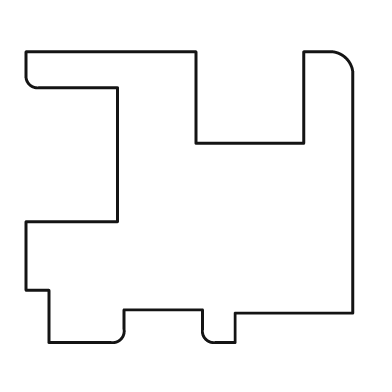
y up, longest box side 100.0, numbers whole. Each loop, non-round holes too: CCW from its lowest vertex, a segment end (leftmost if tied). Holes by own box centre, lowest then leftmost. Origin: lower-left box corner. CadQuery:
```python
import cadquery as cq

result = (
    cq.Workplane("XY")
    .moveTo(7.0, 0.0)
    .lineTo(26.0, 0.0)
    .threePointArc((29.0, 1.0), (30.0, 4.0))
    .lineTo(30.0, 10.0)
    .lineTo(54.0, 10.0)
    .lineTo(54.0, 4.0)
    .threePointArc((55.0, 1.0), (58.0, 0.0))
    .lineTo(64.0, 0.0)
    .lineTo(64.0, 9.0)
    .lineTo(100.0, 9.0)
    .lineTo(100.0, 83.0)
    .threePointArc((98.0, 87.0), (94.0, 89.0))
    .lineTo(85.0, 89.0)
    .lineTo(85.0, 61.0)
    .lineTo(52.0, 61.0)
    .lineTo(52.0, 89.0)
    .lineTo(0.0, 89.0)
    .lineTo(0.0, 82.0)
    .threePointArc((1.0, 79.0), (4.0, 78.0))
    .lineTo(28.0, 78.0)
    .lineTo(28.0, 37.0)
    .lineTo(0.0, 37.0)
    .lineTo(0.0, 16.0)
    .lineTo(7.0, 16.0)
    .close()
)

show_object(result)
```